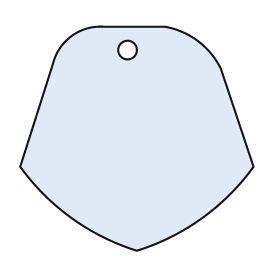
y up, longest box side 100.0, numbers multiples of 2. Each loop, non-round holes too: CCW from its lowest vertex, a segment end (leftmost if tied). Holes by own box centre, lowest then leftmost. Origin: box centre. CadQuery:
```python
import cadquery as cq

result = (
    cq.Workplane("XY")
    .moveTo(0.0, -48.0)
    .threePointArc((28.0, -34.0), (50.0, -12.0))
    .lineTo(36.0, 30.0)
    .threePointArc((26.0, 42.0), (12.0, 48.0))
    .lineTo(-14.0, 48.0)
    .threePointArc((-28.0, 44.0), (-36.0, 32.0))
    .lineTo(-50.0, -12.0)
    .threePointArc((-28.0, -34.0), (0.0, -48.0))
    .close()
    .moveTo(-4.0, 38.0)
    .circle(4.0)
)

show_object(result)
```